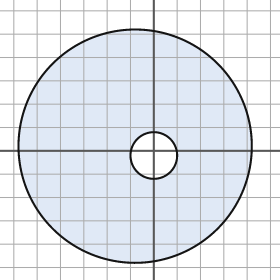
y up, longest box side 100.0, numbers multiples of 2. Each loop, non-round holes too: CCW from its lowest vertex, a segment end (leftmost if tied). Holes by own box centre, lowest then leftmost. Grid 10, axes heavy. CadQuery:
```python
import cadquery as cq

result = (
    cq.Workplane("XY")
    .moveTo(-8.0, 2.0)
    .circle(50.0)
    .moveTo(0.0, -2.0)
    .circle(10.0)
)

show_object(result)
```